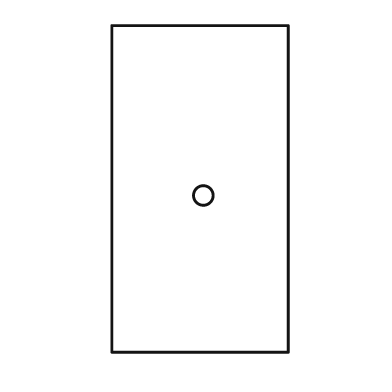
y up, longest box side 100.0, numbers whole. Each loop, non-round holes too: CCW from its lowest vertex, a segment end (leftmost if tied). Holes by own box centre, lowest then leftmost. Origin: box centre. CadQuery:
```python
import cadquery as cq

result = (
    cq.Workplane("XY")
    .moveTo(-27.0, -50.0)
    .lineTo(27.0, -50.0)
    .lineTo(27.0, 50.0)
    .lineTo(-27.0, 50.0)
    .close()
    .moveTo(1.0, -2.0)
    .circle(3.0)
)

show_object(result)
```